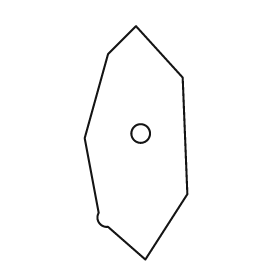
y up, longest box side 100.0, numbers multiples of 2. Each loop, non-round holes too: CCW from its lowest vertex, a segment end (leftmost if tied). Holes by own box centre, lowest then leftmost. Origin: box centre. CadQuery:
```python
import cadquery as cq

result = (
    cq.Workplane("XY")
    .moveTo(4.0, -50.0)
    .lineTo(22.0, -22.0)
    .lineTo(20.0, 28.0)
    .lineTo(0.0, 50.0)
    .lineTo(-12.0, 38.0)
    .lineTo(-22.0, 2.0)
    .lineTo(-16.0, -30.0)
    .threePointArc((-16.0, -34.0), (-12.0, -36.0))
    .close()
    .moveTo(2.0, 4.0)
    .circle(4.0)
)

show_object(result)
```